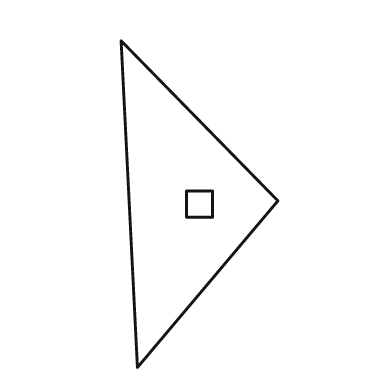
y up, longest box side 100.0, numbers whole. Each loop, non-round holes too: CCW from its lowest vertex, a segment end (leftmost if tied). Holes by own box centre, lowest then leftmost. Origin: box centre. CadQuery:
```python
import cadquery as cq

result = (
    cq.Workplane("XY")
    .moveTo(-19.0, -50.0)
    .lineTo(24.0, 1.0)
    .lineTo(-24.0, 50.0)
    .close()
    .moveTo(-4.0, -4.0)
    .lineTo(4.0, -4.0)
    .lineTo(4.0, 4.0)
    .lineTo(-4.0, 4.0)
    .close()
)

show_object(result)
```